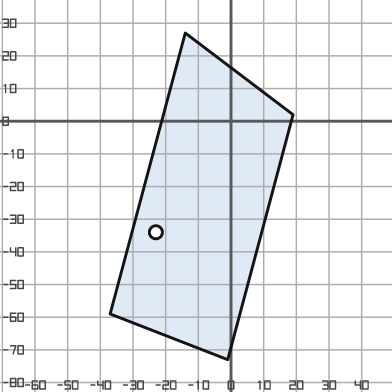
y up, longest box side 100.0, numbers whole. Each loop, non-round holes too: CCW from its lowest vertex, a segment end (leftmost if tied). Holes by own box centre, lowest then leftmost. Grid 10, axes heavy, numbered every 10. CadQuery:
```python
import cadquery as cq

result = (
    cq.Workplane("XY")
    .moveTo(-1.0, -73.0)
    .lineTo(19.0, 2.0)
    .lineTo(-14.0, 27.0)
    .lineTo(-37.0, -59.0)
    .close()
    .moveTo(-23.0, -34.0)
    .circle(2.0)
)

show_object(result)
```